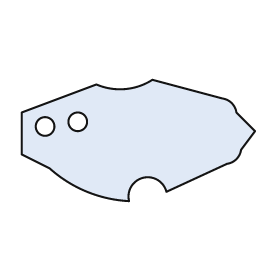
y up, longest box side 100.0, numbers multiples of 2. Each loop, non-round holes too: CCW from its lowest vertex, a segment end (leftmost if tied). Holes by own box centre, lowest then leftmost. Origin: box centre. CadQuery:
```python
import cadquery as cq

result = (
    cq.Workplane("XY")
    .moveTo(-4.0, -26.0)
    .threePointArc((2.0, -16.0), (12.0, -22.0))
    .lineTo(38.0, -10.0)
    .threePointArc((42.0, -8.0), (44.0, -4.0))
    .lineTo(50.0, 4.0)
    .lineTo(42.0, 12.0)
    .threePointArc((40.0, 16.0), (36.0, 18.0))
    .lineTo(6.0, 26.0)
    .threePointArc((-6.0, 22.0), (-18.0, 24.0))
    .lineTo(-50.0, 12.0)
    .lineTo(-50.0, -6.0)
    .lineTo(-38.0, -12.0)
    .threePointArc((-22.0, -22.0), (-4.0, -26.0))
    .close()
    .moveTo(-40.0, 6.0)
    .circle(4.0)
    .moveTo(-26.0, 8.0)
    .circle(4.0)
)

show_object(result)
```